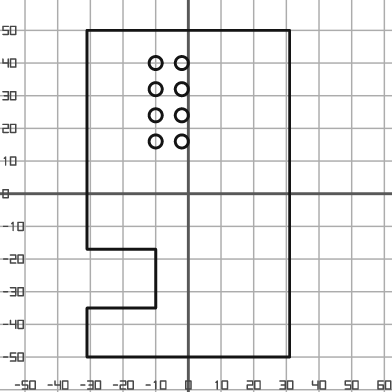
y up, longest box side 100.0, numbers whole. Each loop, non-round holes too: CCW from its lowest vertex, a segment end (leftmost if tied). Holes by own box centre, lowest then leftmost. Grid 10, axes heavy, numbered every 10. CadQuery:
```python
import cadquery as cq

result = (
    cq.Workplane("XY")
    .moveTo(-31.0, -50.0)
    .lineTo(31.0, -50.0)
    .lineTo(31.0, 50.0)
    .lineTo(-31.0, 50.0)
    .lineTo(-31.0, -17.0)
    .lineTo(-10.0, -17.0)
    .lineTo(-10.0, -35.0)
    .lineTo(-31.0, -35.0)
    .close()
    .moveTo(-10.0, 16.0)
    .circle(2.0)
    .moveTo(-2.0, 16.0)
    .circle(2.0)
    .moveTo(-10.0, 24.0)
    .circle(2.0)
    .moveTo(-2.0, 24.0)
    .circle(2.0)
    .moveTo(-10.0, 32.0)
    .circle(2.0)
    .moveTo(-2.0, 32.0)
    .circle(2.0)
    .moveTo(-10.0, 40.0)
    .circle(2.0)
    .moveTo(-2.0, 40.0)
    .circle(2.0)
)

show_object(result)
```